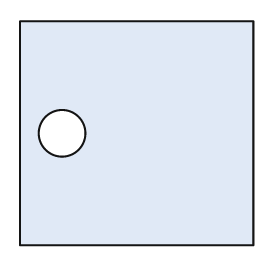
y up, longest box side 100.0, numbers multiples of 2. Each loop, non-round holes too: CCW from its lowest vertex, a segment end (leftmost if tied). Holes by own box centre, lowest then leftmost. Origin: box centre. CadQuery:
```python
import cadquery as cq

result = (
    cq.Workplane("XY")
    .moveTo(-50.0, -48.0)
    .lineTo(50.0, -48.0)
    .lineTo(50.0, 48.0)
    .lineTo(-50.0, 48.0)
    .close()
    .moveTo(-32.0, 0.0)
    .circle(10.0)
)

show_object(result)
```